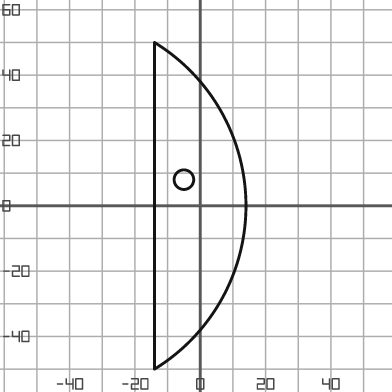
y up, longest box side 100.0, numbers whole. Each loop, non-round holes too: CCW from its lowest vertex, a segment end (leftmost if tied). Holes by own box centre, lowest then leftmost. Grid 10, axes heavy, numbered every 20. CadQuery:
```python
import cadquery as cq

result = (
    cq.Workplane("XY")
    .moveTo(-14.0, -50.0)
    .threePointArc((14.0, 0.0), (-14.0, 50.0))
    .close()
    .moveTo(-5.0, 8.0)
    .circle(3.0)
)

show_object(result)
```